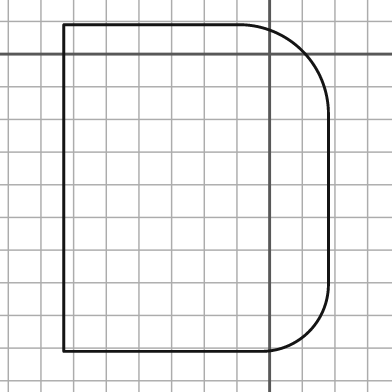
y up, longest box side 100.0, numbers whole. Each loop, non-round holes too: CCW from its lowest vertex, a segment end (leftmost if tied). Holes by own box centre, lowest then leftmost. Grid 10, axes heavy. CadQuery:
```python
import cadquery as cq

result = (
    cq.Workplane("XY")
    .moveTo(-63.0, -91.0)
    .lineTo(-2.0, -91.0)
    .threePointArc((12.0, -85.0), (18.0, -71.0))
    .lineTo(18.0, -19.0)
    .threePointArc((10.0, 1.0), (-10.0, 9.0))
    .lineTo(-63.0, 9.0)
    .close()
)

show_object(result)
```